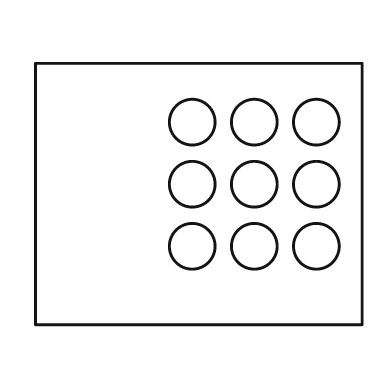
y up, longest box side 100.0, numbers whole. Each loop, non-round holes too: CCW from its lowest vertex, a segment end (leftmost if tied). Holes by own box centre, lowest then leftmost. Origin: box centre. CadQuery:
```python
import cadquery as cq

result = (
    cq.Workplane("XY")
    .moveTo(-50.0, -40.0)
    .lineTo(50.0, -40.0)
    .lineTo(50.0, 40.0)
    .lineTo(-50.0, 40.0)
    .close()
    .moveTo(-2.0, -16.0)
    .circle(7.0)
    .moveTo(17.0, -16.0)
    .circle(7.0)
    .moveTo(36.0, -16.0)
    .circle(7.0)
    .moveTo(-2.0, 3.0)
    .circle(7.0)
    .moveTo(17.0, 3.0)
    .circle(7.0)
    .moveTo(36.0, 3.0)
    .circle(7.0)
    .moveTo(-2.0, 22.0)
    .circle(7.0)
    .moveTo(17.0, 22.0)
    .circle(7.0)
    .moveTo(36.0, 22.0)
    .circle(7.0)
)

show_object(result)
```